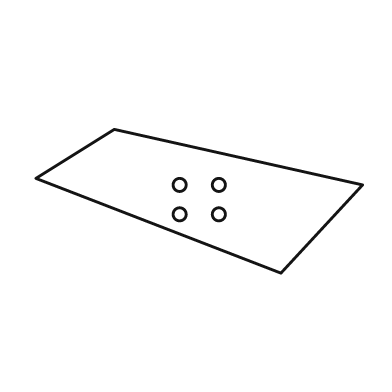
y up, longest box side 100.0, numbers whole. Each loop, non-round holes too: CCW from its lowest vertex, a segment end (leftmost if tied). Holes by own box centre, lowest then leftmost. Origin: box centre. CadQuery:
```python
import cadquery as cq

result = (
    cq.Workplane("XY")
    .moveTo(25.0, -22.0)
    .lineTo(50.0, 5.0)
    .lineTo(-26.0, 22.0)
    .lineTo(-50.0, 7.0)
    .close()
    .moveTo(-6.0, -4.0)
    .circle(2.0)
    .moveTo(6.0, -4.0)
    .circle(2.0)
    .moveTo(-6.0, 5.0)
    .circle(2.0)
    .moveTo(6.0, 5.0)
    .circle(2.0)
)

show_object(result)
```